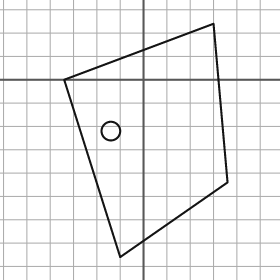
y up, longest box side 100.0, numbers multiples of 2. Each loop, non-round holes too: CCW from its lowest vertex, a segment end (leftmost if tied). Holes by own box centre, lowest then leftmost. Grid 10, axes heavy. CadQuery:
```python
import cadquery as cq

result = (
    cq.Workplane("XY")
    .moveTo(-10.0, -76.0)
    .lineTo(36.0, -44.0)
    .lineTo(30.0, 24.0)
    .lineTo(-34.0, 0.0)
    .close()
    .moveTo(-14.0, -22.0)
    .circle(4.0)
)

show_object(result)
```